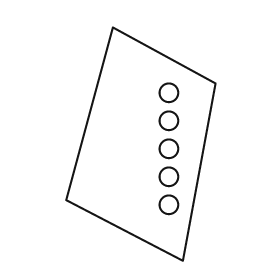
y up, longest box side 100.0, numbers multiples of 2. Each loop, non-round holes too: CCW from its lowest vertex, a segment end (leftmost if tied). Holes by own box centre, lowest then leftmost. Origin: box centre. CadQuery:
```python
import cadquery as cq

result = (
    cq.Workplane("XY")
    .moveTo(18.0, -50.0)
    .lineTo(32.0, 26.0)
    .lineTo(-12.0, 50.0)
    .lineTo(-32.0, -24.0)
    .close()
    .moveTo(12.0, -26.0)
    .circle(4.0)
    .moveTo(12.0, -14.0)
    .circle(4.0)
    .moveTo(12.0, -2.0)
    .circle(4.0)
    .moveTo(12.0, 10.0)
    .circle(4.0)
    .moveTo(12.0, 22.0)
    .circle(4.0)
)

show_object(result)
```